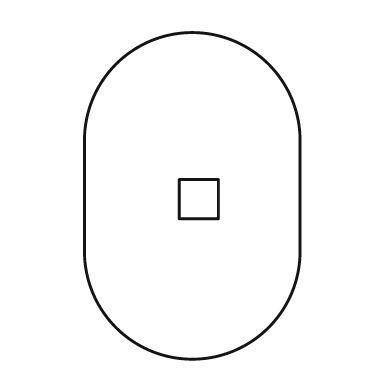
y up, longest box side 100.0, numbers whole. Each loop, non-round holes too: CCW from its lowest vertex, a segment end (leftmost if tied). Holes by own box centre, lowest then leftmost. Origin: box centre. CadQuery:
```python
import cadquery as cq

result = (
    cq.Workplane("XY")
    .moveTo(-33.0, -17.0)
    .threePointArc((0.0, -50.0), (33.0, -17.0))
    .lineTo(33.0, 17.0)
    .threePointArc((0.0, 50.0), (-33.0, 17.0))
    .close()
    .moveTo(-4.0, -7.0)
    .lineTo(8.0, -7.0)
    .lineTo(8.0, 5.0)
    .lineTo(-4.0, 5.0)
    .close()
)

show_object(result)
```